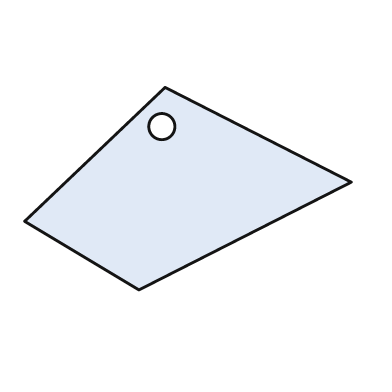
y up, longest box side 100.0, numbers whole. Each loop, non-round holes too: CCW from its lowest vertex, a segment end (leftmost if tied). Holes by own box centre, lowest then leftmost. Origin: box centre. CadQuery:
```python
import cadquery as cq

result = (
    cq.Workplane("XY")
    .moveTo(-15.0, -31.0)
    .lineTo(50.0, 2.0)
    .lineTo(-7.0, 31.0)
    .lineTo(-50.0, -10.0)
    .close()
    .moveTo(-8.0, 19.0)
    .circle(4.0)
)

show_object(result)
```